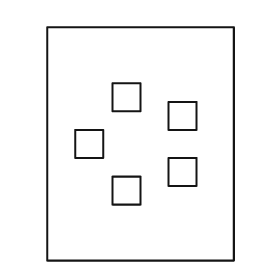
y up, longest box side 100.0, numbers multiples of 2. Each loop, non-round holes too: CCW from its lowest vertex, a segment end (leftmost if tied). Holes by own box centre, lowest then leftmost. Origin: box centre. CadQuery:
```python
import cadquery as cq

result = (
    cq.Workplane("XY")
    .moveTo(-40.0, -50.0)
    .lineTo(40.0, -50.0)
    .lineTo(40.0, 50.0)
    .lineTo(-40.0, 50.0)
    .close()
    .moveTo(-12.0, -26.0)
    .lineTo(0.0, -26.0)
    .lineTo(0.0, -14.0)
    .lineTo(-12.0, -14.0)
    .close()
    .moveTo(12.0, -18.0)
    .lineTo(24.0, -18.0)
    .lineTo(24.0, -6.0)
    .lineTo(12.0, -6.0)
    .close()
    .moveTo(-28.0, -6.0)
    .lineTo(-16.0, -6.0)
    .lineTo(-16.0, 6.0)
    .lineTo(-28.0, 6.0)
    .close()
    .moveTo(12.0, 6.0)
    .lineTo(24.0, 6.0)
    .lineTo(24.0, 18.0)
    .lineTo(12.0, 18.0)
    .close()
    .moveTo(-12.0, 14.0)
    .lineTo(0.0, 14.0)
    .lineTo(0.0, 26.0)
    .lineTo(-12.0, 26.0)
    .close()
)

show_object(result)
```